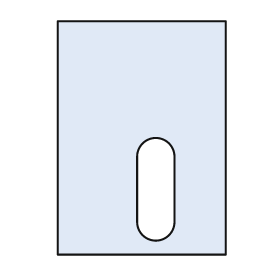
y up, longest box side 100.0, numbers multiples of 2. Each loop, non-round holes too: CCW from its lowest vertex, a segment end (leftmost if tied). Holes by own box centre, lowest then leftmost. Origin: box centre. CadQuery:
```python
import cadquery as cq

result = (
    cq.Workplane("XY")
    .moveTo(-36.0, -50.0)
    .lineTo(36.0, -50.0)
    .lineTo(36.0, 50.0)
    .lineTo(-36.0, 50.0)
    .close()
    .moveTo(-2.0, -36.0)
    .threePointArc((6.0, -44.0), (14.0, -36.0))
    .lineTo(14.0, -8.0)
    .threePointArc((6.0, 0.0), (-2.0, -8.0))
    .close()
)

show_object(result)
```